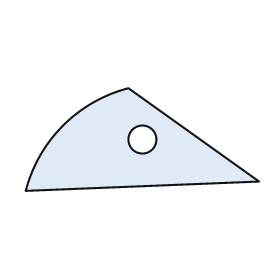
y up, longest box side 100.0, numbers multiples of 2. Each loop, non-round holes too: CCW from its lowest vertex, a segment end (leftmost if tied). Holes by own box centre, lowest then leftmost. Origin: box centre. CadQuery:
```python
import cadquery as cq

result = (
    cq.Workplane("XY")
    .moveTo(-50.0, -22.0)
    .lineTo(50.0, -18.0)
    .lineTo(-6.0, 22.0)
    .threePointArc((-34.0, 6.0), (-50.0, -22.0))
    .close()
    .moveTo(0.0, 0.0)
    .circle(6.0)
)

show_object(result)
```